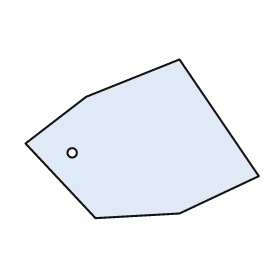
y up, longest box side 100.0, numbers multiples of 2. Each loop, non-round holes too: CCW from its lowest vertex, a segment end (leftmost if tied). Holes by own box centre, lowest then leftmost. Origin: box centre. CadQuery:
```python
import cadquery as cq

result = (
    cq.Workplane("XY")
    .moveTo(-20.0, -34.0)
    .lineTo(16.0, -32.0)
    .lineTo(50.0, -16.0)
    .lineTo(16.0, 34.0)
    .lineTo(-24.0, 18.0)
    .lineTo(-50.0, -2.0)
    .close()
    .moveTo(-30.0, -6.0)
    .circle(2.0)
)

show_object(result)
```